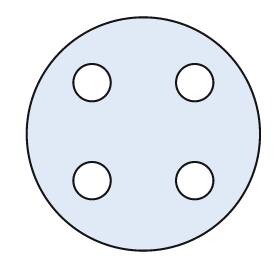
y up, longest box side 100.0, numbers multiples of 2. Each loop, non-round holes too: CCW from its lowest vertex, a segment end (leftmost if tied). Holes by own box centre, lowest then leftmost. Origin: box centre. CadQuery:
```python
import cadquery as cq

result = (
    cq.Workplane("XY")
    .moveTo(0.0, 0.0)
    .circle(50.0)
    .moveTo(-22.0, -20.0)
    .circle(8.0)
    .moveTo(22.0, -20.0)
    .circle(8.0)
    .moveTo(-22.0, 22.0)
    .circle(8.0)
    .moveTo(22.0, 22.0)
    .circle(8.0)
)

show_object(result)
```